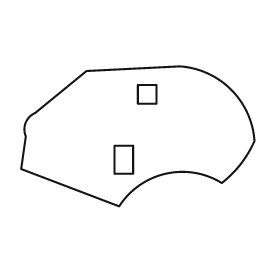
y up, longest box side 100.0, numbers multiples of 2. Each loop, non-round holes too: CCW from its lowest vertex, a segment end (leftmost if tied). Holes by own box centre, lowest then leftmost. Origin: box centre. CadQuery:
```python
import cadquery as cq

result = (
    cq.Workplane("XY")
    .moveTo(-8.0, -30.0)
    .threePointArc((12.0, -16.0), (36.0, -20.0))
    .threePointArc((44.0, -12.0), (50.0, -2.0))
    .threePointArc((40.0, 20.0), (18.0, 30.0))
    .lineTo(-22.0, 28.0)
    .lineTo(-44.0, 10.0)
    .threePointArc((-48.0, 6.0), (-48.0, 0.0))
    .lineTo(-50.0, -14.0)
    .close()
    .moveTo(-10.0, -16.0)
    .lineTo(-2.0, -16.0)
    .lineTo(-2.0, -4.0)
    .lineTo(-10.0, -4.0)
    .close()
    .moveTo(0.0, 14.0)
    .lineTo(8.0, 14.0)
    .lineTo(8.0, 22.0)
    .lineTo(0.0, 22.0)
    .close()
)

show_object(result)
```